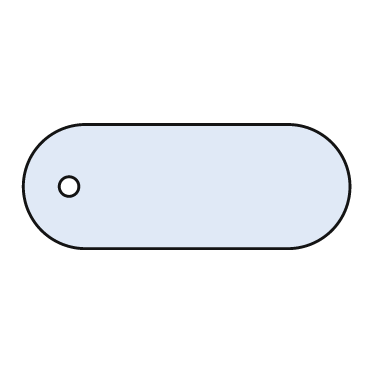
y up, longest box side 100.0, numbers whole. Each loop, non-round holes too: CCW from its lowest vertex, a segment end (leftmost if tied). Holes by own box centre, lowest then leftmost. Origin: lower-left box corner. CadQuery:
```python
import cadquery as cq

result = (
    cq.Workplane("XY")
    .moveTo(19.0, 0.0)
    .lineTo(81.0, 0.0)
    .threePointArc((100.0, 19.0), (81.0, 38.0))
    .lineTo(19.0, 38.0)
    .threePointArc((0.0, 19.0), (19.0, 0.0))
    .close()
    .moveTo(14.0, 19.0)
    .circle(3.0)
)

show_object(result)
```